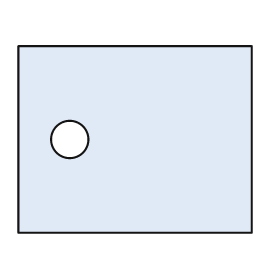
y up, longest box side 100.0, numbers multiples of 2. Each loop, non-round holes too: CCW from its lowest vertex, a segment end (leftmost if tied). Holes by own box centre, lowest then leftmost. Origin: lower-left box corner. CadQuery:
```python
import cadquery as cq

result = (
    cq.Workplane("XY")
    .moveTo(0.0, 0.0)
    .lineTo(100.0, 0.0)
    .lineTo(100.0, 80.0)
    .lineTo(0.0, 80.0)
    .close()
    .moveTo(22.0, 40.0)
    .circle(8.0)
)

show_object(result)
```